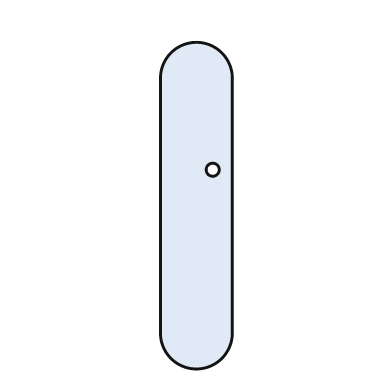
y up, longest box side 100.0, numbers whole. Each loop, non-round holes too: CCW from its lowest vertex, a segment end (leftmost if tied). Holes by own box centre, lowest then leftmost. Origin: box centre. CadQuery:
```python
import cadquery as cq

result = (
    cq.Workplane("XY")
    .moveTo(-11.0, -39.0)
    .threePointArc((0.0, -50.0), (11.0, -39.0))
    .lineTo(11.0, 39.0)
    .threePointArc((0.0, 50.0), (-11.0, 39.0))
    .close()
    .moveTo(5.0, 11.0)
    .circle(2.0)
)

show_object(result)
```